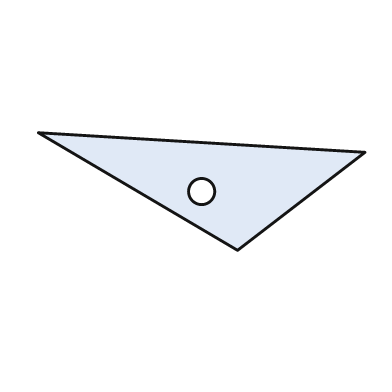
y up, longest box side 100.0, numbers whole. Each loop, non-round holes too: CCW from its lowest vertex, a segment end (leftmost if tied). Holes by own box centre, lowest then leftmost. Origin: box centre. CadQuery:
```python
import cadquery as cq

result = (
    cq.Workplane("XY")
    .moveTo(11.0, -18.0)
    .lineTo(50.0, 12.0)
    .lineTo(-50.0, 18.0)
    .close()
    .moveTo(0.0, 0.0)
    .circle(4.0)
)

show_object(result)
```